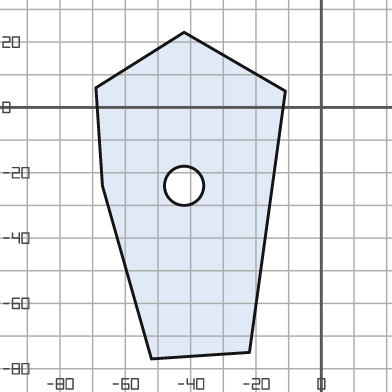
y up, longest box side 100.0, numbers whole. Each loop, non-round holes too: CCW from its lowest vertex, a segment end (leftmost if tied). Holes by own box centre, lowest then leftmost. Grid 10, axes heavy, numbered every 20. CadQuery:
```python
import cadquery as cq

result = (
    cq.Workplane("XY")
    .moveTo(-52.0, -77.0)
    .lineTo(-22.0, -75.0)
    .lineTo(-11.0, 5.0)
    .lineTo(-42.0, 23.0)
    .lineTo(-69.0, 6.0)
    .lineTo(-67.0, -24.0)
    .close()
    .moveTo(-42.0, -24.0)
    .circle(6.0)
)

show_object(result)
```